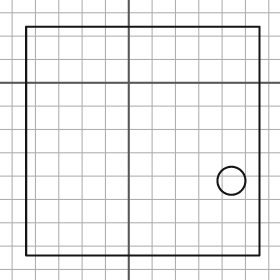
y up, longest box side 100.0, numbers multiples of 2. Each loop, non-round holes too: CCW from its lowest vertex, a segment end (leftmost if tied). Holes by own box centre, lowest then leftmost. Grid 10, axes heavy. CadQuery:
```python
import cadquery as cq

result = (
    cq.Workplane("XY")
    .moveTo(-44.0, -74.0)
    .lineTo(56.0, -74.0)
    .lineTo(56.0, 24.0)
    .lineTo(-44.0, 24.0)
    .close()
    .moveTo(44.0, -42.0)
    .circle(6.0)
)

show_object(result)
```